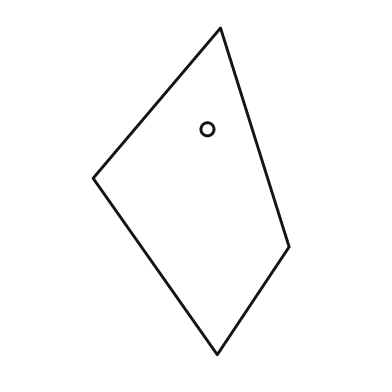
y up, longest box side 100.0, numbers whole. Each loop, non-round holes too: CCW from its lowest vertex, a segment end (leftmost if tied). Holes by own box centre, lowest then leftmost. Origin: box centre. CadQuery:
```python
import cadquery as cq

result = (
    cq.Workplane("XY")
    .moveTo(8.0, -50.0)
    .lineTo(30.0, -17.0)
    .lineTo(9.0, 50.0)
    .lineTo(-30.0, 4.0)
    .close()
    .moveTo(5.0, 19.0)
    .circle(2.0)
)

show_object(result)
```